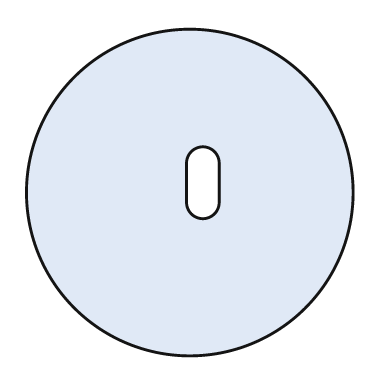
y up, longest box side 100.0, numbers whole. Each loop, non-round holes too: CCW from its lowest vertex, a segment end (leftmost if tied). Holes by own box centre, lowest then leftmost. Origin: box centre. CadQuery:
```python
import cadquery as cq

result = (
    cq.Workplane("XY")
    .moveTo(0.0, 0.0)
    .circle(50.0)
    .moveTo(-1.0, -3.0)
    .threePointArc((4.0, -8.0), (9.0, -3.0))
    .lineTo(9.0, 9.0)
    .threePointArc((4.0, 14.0), (-1.0, 9.0))
    .close()
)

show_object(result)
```